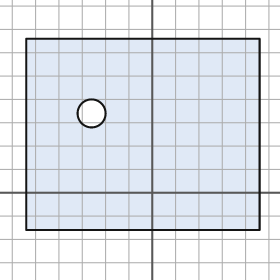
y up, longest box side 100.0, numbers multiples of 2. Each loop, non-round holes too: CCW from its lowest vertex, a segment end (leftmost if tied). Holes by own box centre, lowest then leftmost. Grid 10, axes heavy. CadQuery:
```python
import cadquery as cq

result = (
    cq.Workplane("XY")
    .moveTo(-54.0, -16.0)
    .lineTo(46.0, -16.0)
    .lineTo(46.0, 66.0)
    .lineTo(-54.0, 66.0)
    .close()
    .moveTo(-26.0, 34.0)
    .circle(6.0)
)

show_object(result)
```